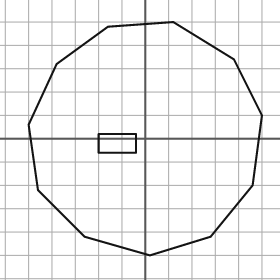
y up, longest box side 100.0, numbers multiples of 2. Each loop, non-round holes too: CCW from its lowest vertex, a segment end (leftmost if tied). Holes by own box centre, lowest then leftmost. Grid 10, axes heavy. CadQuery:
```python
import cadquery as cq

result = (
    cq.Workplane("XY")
    .moveTo(2.0, -50.0)
    .lineTo(28.0, -42.0)
    .lineTo(46.0, -20.0)
    .lineTo(50.0, 10.0)
    .lineTo(38.0, 34.0)
    .lineTo(12.0, 50.0)
    .lineTo(-16.0, 48.0)
    .lineTo(-38.0, 32.0)
    .lineTo(-50.0, 6.0)
    .lineTo(-46.0, -22.0)
    .lineTo(-26.0, -42.0)
    .close()
    .moveTo(-20.0, -6.0)
    .lineTo(-4.0, -6.0)
    .lineTo(-4.0, 2.0)
    .lineTo(-20.0, 2.0)
    .close()
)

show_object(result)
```